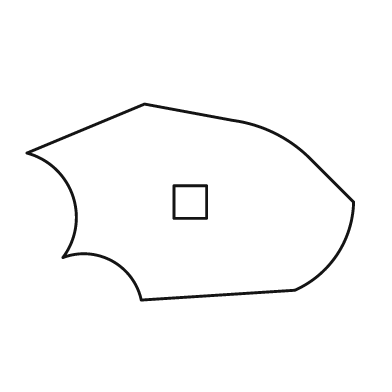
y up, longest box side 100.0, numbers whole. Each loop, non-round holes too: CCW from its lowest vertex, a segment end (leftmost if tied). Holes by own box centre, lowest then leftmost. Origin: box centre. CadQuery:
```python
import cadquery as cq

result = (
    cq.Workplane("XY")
    .moveTo(-15.0, -30.0)
    .lineTo(32.0, -27.0)
    .threePointArc((45.0, -16.0), (50.0, 0.0))
    .lineTo(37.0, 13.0)
    .threePointArc((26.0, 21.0), (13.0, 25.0))
    .lineTo(-14.0, 30.0)
    .lineTo(-50.0, 15.0)
    .threePointArc((-36.0, 2.0), (-39.0, -17.0))
    .threePointArc((-24.0, -18.0), (-15.0, -30.0))
    .close()
    .moveTo(-5.0, -5.0)
    .lineTo(5.0, -5.0)
    .lineTo(5.0, 5.0)
    .lineTo(-5.0, 5.0)
    .close()
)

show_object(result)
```